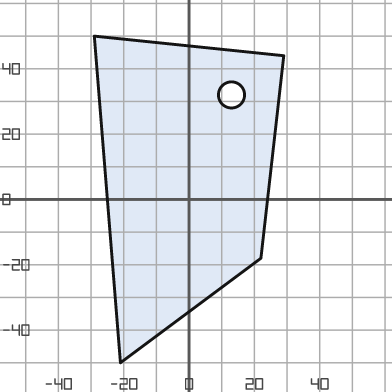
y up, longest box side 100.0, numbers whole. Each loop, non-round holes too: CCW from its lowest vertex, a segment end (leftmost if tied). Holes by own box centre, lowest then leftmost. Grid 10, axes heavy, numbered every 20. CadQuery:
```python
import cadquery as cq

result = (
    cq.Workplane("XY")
    .moveTo(-21.0, -50.0)
    .lineTo(22.0, -18.0)
    .lineTo(29.0, 44.0)
    .lineTo(-29.0, 50.0)
    .close()
    .moveTo(13.0, 32.0)
    .circle(4.0)
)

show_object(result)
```